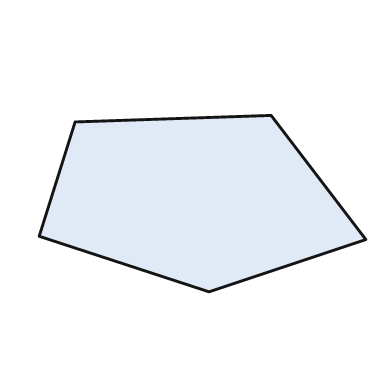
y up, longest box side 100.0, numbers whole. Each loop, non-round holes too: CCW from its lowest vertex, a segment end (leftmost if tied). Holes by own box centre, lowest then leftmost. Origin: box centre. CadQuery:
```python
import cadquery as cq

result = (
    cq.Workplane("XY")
    .moveTo(2.0, -27.0)
    .lineTo(50.0, -11.0)
    .lineTo(21.0, 27.0)
    .lineTo(-39.0, 25.0)
    .lineTo(-50.0, -10.0)
    .close()
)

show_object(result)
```